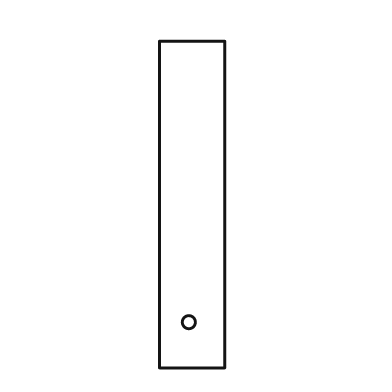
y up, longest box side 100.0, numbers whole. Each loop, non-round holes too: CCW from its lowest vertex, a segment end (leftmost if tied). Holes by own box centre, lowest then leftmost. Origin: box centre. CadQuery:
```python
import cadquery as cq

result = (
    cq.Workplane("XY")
    .moveTo(-10.0, -50.0)
    .lineTo(10.0, -50.0)
    .lineTo(10.0, 50.0)
    .lineTo(-10.0, 50.0)
    .close()
    .moveTo(-1.0, -36.0)
    .circle(2.0)
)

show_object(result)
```